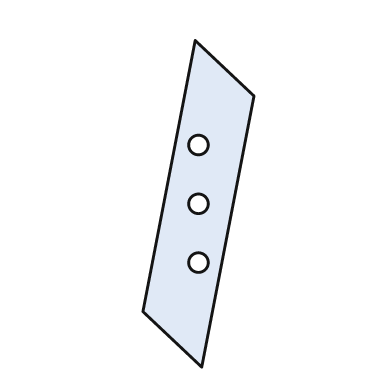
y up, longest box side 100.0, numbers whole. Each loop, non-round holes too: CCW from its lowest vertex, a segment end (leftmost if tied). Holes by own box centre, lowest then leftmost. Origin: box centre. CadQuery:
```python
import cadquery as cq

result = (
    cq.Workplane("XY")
    .moveTo(1.0, -50.0)
    .lineTo(17.0, 33.0)
    .lineTo(-1.0, 50.0)
    .lineTo(-17.0, -33.0)
    .close()
    .moveTo(0.0, -18.0)
    .circle(3.0)
    .moveTo(0.0, 0.0)
    .circle(3.0)
    .moveTo(0.0, 18.0)
    .circle(3.0)
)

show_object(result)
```